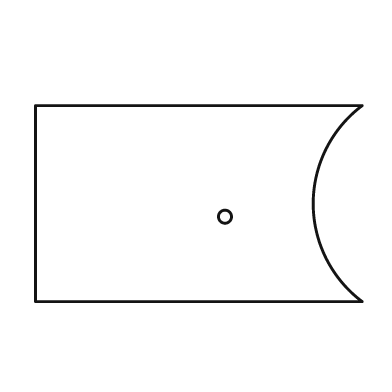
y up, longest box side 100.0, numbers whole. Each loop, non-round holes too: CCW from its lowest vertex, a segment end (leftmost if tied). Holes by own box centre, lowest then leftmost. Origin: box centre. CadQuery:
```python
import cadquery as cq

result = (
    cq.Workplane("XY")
    .moveTo(-50.0, -30.0)
    .lineTo(50.0, -30.0)
    .threePointArc((35.0, 0.0), (50.0, 30.0))
    .lineTo(-50.0, 30.0)
    .close()
    .moveTo(8.0, -4.0)
    .circle(2.0)
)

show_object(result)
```